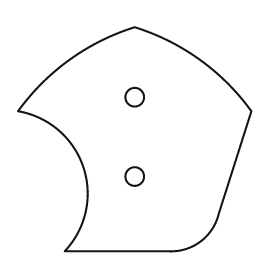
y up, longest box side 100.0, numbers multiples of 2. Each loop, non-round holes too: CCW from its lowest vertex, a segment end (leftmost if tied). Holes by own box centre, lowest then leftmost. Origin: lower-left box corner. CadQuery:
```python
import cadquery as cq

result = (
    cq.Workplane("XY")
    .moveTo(20.0, 0.0)
    .lineTo(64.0, 0.0)
    .threePointArc((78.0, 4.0), (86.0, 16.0))
    .lineTo(100.0, 60.0)
    .threePointArc((78.0, 82.0), (50.0, 96.0))
    .threePointArc((22.0, 82.0), (0.0, 60.0))
    .threePointArc((28.0, 36.0), (20.0, 0.0))
    .close()
    .moveTo(50.0, 32.0)
    .circle(4.0)
    .moveTo(50.0, 66.0)
    .circle(4.0)
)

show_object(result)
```